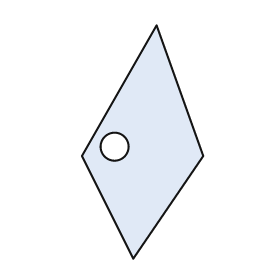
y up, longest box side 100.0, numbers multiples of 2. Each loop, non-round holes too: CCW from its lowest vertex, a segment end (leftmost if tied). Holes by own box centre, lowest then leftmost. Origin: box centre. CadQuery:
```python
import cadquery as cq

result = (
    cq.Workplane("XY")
    .moveTo(-4.0, -50.0)
    .lineTo(26.0, -6.0)
    .lineTo(6.0, 50.0)
    .lineTo(-26.0, -6.0)
    .close()
    .moveTo(-12.0, -2.0)
    .circle(6.0)
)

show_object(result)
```